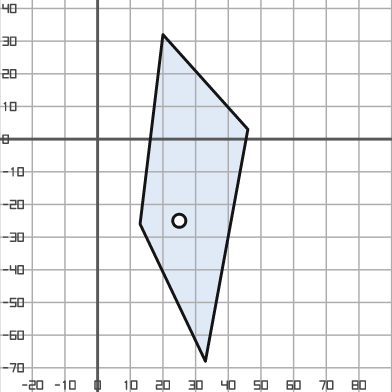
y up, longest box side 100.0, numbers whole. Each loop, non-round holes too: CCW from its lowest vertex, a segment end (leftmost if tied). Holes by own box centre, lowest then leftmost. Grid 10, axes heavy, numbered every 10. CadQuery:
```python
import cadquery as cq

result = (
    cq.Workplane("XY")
    .moveTo(33.0, -68.0)
    .lineTo(46.0, 3.0)
    .lineTo(20.0, 32.0)
    .lineTo(13.0, -26.0)
    .close()
    .moveTo(25.0, -25.0)
    .circle(2.0)
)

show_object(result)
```